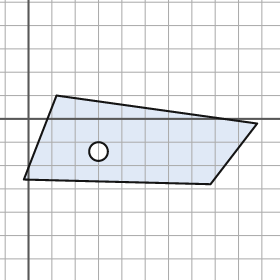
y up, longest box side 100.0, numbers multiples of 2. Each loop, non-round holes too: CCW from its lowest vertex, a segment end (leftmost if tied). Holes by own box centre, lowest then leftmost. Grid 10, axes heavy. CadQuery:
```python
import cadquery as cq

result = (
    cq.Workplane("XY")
    .moveTo(78.0, -28.0)
    .lineTo(98.0, -2.0)
    .lineTo(12.0, 10.0)
    .lineTo(-2.0, -26.0)
    .close()
    .moveTo(30.0, -14.0)
    .circle(4.0)
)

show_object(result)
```